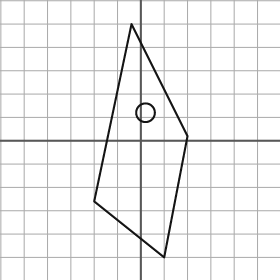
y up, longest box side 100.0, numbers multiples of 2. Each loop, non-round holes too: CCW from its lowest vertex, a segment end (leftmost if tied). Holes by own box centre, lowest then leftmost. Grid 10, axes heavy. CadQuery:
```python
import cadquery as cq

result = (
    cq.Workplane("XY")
    .moveTo(10.0, -50.0)
    .lineTo(20.0, 2.0)
    .lineTo(-4.0, 50.0)
    .lineTo(-20.0, -26.0)
    .close()
    .moveTo(2.0, 12.0)
    .circle(4.0)
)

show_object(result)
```